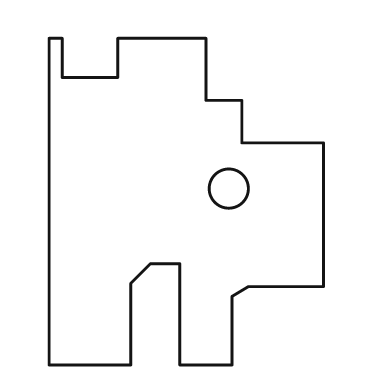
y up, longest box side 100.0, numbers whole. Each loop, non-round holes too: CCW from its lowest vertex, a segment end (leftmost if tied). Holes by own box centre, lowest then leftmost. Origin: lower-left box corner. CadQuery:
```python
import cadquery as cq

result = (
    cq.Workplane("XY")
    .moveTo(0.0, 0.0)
    .lineTo(25.0, 0.0)
    .lineTo(25.0, 25.0)
    .lineTo(31.0, 31.0)
    .lineTo(40.0, 31.0)
    .lineTo(40.0, 0.0)
    .lineTo(56.0, 0.0)
    .lineTo(56.0, 21.0)
    .lineTo(61.0, 24.0)
    .lineTo(84.0, 24.0)
    .lineTo(84.0, 68.0)
    .lineTo(59.0, 68.0)
    .lineTo(59.0, 81.0)
    .lineTo(48.0, 81.0)
    .lineTo(48.0, 100.0)
    .lineTo(21.0, 100.0)
    .lineTo(21.0, 88.0)
    .lineTo(4.0, 88.0)
    .lineTo(4.0, 100.0)
    .lineTo(0.0, 100.0)
    .close()
    .moveTo(55.0, 54.0)
    .circle(6.0)
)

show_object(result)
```